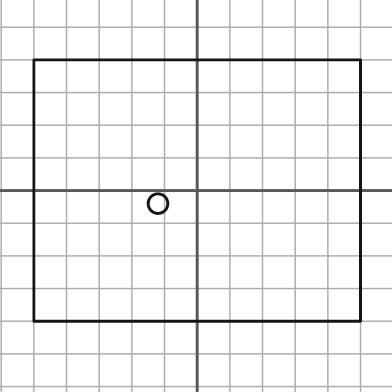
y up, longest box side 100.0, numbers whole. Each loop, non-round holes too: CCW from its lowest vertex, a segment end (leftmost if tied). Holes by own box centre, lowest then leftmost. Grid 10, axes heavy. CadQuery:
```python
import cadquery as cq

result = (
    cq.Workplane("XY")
    .moveTo(-50.0, -40.0)
    .lineTo(50.0, -40.0)
    .lineTo(50.0, 40.0)
    .lineTo(-50.0, 40.0)
    .close()
    .moveTo(-12.0, -4.0)
    .circle(3.0)
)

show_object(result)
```